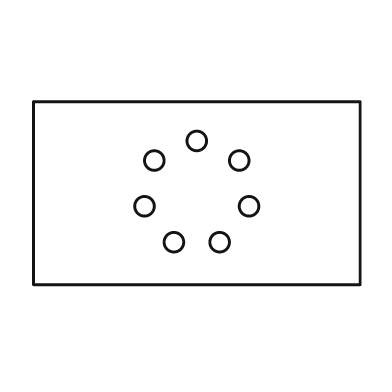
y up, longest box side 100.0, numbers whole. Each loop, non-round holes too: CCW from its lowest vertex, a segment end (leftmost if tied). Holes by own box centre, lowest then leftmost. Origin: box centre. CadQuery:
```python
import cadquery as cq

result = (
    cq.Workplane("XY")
    .moveTo(-50.0, -28.0)
    .lineTo(50.0, -28.0)
    .lineTo(50.0, 28.0)
    .lineTo(-50.0, 28.0)
    .close()
    .moveTo(-7.0, -15.0)
    .circle(3.0)
    .moveTo(7.0, -15.0)
    .circle(3.0)
    .moveTo(-16.0, -4.0)
    .circle(3.0)
    .moveTo(16.0, -4.0)
    .circle(3.0)
    .moveTo(-13.0, 10.0)
    .circle(3.0)
    .moveTo(13.0, 10.0)
    .circle(3.0)
    .moveTo(0.0, 16.0)
    .circle(3.0)
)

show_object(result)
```